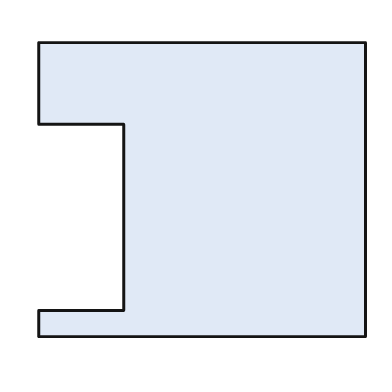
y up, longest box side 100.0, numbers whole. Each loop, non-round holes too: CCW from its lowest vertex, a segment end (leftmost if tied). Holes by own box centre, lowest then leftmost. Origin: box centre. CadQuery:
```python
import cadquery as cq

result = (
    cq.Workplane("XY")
    .moveTo(-50.0, -45.0)
    .lineTo(50.0, -45.0)
    .lineTo(50.0, 45.0)
    .lineTo(-50.0, 45.0)
    .lineTo(-50.0, 20.0)
    .lineTo(-24.0, 20.0)
    .lineTo(-24.0, -37.0)
    .lineTo(-50.0, -37.0)
    .close()
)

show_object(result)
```